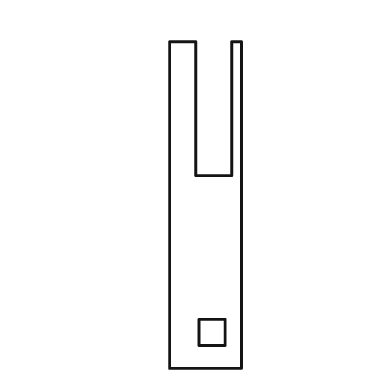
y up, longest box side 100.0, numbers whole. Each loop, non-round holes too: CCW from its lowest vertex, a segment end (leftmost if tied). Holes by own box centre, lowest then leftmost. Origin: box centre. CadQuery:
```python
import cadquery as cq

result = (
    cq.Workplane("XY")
    .moveTo(-11.0, -50.0)
    .lineTo(11.0, -50.0)
    .lineTo(11.0, 50.0)
    .lineTo(8.0, 50.0)
    .lineTo(8.0, 9.0)
    .lineTo(-3.0, 9.0)
    .lineTo(-3.0, 50.0)
    .lineTo(-11.0, 50.0)
    .close()
    .moveTo(-2.0, -43.0)
    .lineTo(6.0, -43.0)
    .lineTo(6.0, -35.0)
    .lineTo(-2.0, -35.0)
    .close()
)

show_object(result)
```